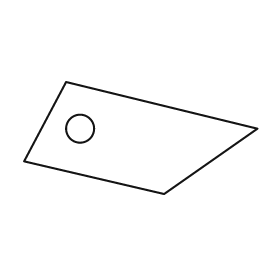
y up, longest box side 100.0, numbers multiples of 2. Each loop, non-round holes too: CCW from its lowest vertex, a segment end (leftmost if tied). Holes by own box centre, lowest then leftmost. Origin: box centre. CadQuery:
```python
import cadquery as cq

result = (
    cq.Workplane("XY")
    .moveTo(10.0, -24.0)
    .lineTo(50.0, 4.0)
    .lineTo(-32.0, 24.0)
    .lineTo(-50.0, -10.0)
    .close()
    .moveTo(-26.0, 4.0)
    .circle(6.0)
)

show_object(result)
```